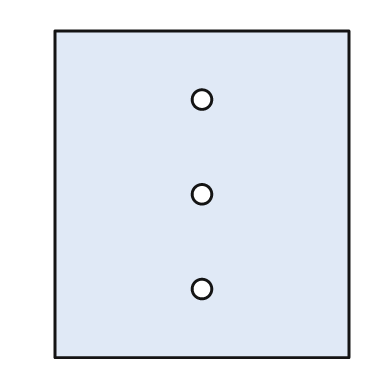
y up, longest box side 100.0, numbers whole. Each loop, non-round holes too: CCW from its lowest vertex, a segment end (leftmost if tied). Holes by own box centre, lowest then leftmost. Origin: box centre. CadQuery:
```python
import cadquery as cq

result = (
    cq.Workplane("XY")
    .moveTo(-45.0, -50.0)
    .lineTo(45.0, -50.0)
    .lineTo(45.0, 50.0)
    .lineTo(-45.0, 50.0)
    .close()
    .moveTo(0.0, -29.0)
    .circle(3.0)
    .moveTo(0.0, 0.0)
    .circle(3.0)
    .moveTo(0.0, 29.0)
    .circle(3.0)
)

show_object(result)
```